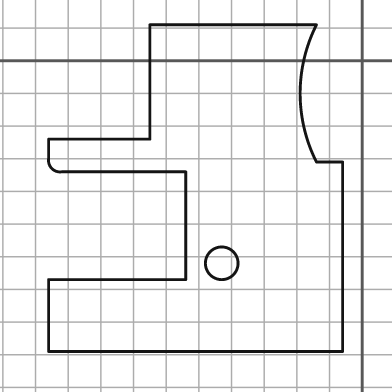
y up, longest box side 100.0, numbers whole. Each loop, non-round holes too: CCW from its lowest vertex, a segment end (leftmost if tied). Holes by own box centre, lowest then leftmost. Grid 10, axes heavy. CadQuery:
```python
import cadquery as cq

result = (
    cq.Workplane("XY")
    .moveTo(-96.0, -89.0)
    .lineTo(-6.0, -89.0)
    .lineTo(-6.0, -31.0)
    .lineTo(-14.0, -31.0)
    .threePointArc((-19.0, -10.0), (-14.0, 11.0))
    .lineTo(-65.0, 11.0)
    .lineTo(-65.0, -24.0)
    .lineTo(-96.0, -24.0)
    .lineTo(-96.0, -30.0)
    .threePointArc((-95.0, -33.0), (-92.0, -34.0))
    .lineTo(-54.0, -34.0)
    .lineTo(-54.0, -67.0)
    .lineTo(-96.0, -67.0)
    .close()
    .moveTo(-43.0, -62.0)
    .circle(5.0)
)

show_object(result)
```